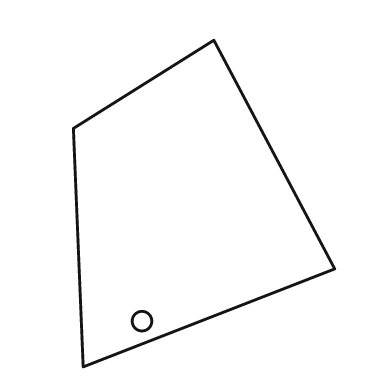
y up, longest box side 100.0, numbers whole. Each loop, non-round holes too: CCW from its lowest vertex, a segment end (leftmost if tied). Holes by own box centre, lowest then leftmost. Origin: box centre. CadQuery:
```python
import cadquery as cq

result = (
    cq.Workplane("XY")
    .moveTo(-37.0, -50.0)
    .lineTo(40.0, -20.0)
    .lineTo(3.0, 50.0)
    .lineTo(-40.0, 23.0)
    .close()
    .moveTo(-19.0, -36.0)
    .circle(3.0)
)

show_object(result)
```